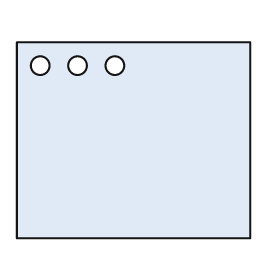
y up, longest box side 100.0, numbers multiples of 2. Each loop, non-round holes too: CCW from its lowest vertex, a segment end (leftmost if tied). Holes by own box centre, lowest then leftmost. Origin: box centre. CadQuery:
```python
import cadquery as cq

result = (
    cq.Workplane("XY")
    .moveTo(-50.0, -42.0)
    .lineTo(50.0, -42.0)
    .lineTo(50.0, 42.0)
    .lineTo(-50.0, 42.0)
    .close()
    .moveTo(-40.0, 32.0)
    .circle(4.0)
    .moveTo(-24.0, 32.0)
    .circle(4.0)
    .moveTo(-8.0, 32.0)
    .circle(4.0)
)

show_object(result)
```